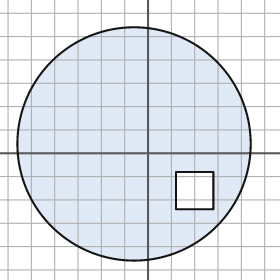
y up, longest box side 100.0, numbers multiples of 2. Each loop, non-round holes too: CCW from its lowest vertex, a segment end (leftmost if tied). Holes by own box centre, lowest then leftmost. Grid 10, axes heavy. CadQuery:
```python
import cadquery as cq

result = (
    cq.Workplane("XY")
    .moveTo(-6.0, 4.0)
    .circle(50.0)
    .moveTo(12.0, -24.0)
    .lineTo(28.0, -24.0)
    .lineTo(28.0, -8.0)
    .lineTo(12.0, -8.0)
    .close()
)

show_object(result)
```